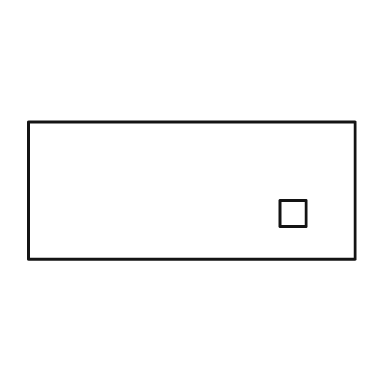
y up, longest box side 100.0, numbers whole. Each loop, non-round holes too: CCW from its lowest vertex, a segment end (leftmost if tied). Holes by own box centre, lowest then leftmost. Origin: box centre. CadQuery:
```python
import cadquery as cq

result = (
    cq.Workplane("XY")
    .moveTo(-50.0, -21.0)
    .lineTo(50.0, -21.0)
    .lineTo(50.0, 21.0)
    .lineTo(-50.0, 21.0)
    .close()
    .moveTo(27.0, -11.0)
    .lineTo(35.0, -11.0)
    .lineTo(35.0, -3.0)
    .lineTo(27.0, -3.0)
    .close()
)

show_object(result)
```